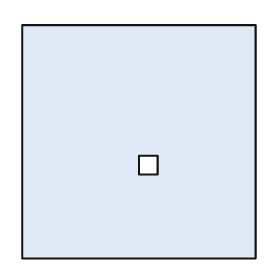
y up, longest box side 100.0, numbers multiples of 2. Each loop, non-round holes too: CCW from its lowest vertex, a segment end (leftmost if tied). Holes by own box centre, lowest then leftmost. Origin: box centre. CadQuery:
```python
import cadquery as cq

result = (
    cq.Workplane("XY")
    .moveTo(-50.0, -50.0)
    .lineTo(50.0, -50.0)
    .lineTo(50.0, 50.0)
    .lineTo(-50.0, 50.0)
    .close()
    .moveTo(0.0, -14.0)
    .lineTo(8.0, -14.0)
    .lineTo(8.0, -6.0)
    .lineTo(0.0, -6.0)
    .close()
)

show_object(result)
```